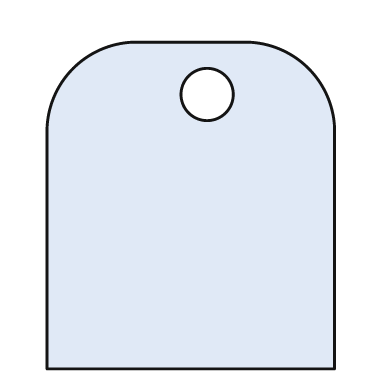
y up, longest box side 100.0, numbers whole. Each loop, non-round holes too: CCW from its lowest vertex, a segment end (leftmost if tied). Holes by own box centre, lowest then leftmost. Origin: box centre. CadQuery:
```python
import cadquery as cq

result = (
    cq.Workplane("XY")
    .moveTo(-44.0, -50.0)
    .lineTo(44.0, -50.0)
    .lineTo(44.0, 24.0)
    .threePointArc((36.0, 42.0), (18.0, 50.0))
    .lineTo(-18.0, 50.0)
    .threePointArc((-36.0, 42.0), (-44.0, 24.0))
    .close()
    .moveTo(5.0, 34.0)
    .circle(8.0)
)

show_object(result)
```